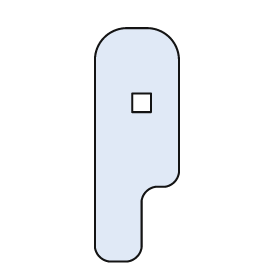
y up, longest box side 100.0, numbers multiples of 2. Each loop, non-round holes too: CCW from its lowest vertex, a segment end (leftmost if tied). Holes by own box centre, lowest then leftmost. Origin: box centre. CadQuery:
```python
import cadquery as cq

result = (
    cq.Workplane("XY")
    .moveTo(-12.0, -50.0)
    .lineTo(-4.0, -50.0)
    .threePointArc((0.0, -48.0), (2.0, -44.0))
    .lineTo(2.0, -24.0)
    .threePointArc((4.0, -20.0), (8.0, -18.0))
    .lineTo(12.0, -18.0)
    .threePointArc((16.0, -16.0), (18.0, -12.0))
    .lineTo(18.0, 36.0)
    .threePointArc((14.0, 46.0), (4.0, 50.0))
    .lineTo(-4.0, 50.0)
    .threePointArc((-14.0, 46.0), (-18.0, 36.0))
    .lineTo(-18.0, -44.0)
    .threePointArc((-16.0, -48.0), (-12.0, -50.0))
    .close()
    .moveTo(-2.0, 14.0)
    .lineTo(6.0, 14.0)
    .lineTo(6.0, 22.0)
    .lineTo(-2.0, 22.0)
    .close()
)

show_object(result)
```